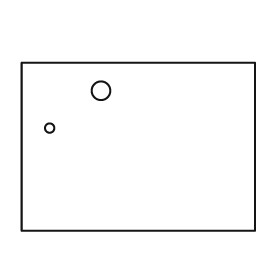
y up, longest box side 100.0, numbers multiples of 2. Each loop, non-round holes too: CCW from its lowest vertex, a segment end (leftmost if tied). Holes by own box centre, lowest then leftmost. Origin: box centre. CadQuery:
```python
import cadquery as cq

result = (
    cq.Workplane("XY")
    .moveTo(-50.0, -36.0)
    .lineTo(50.0, -36.0)
    .lineTo(50.0, 36.0)
    .lineTo(-50.0, 36.0)
    .close()
    .moveTo(-38.0, 8.0)
    .circle(2.0)
    .moveTo(-16.0, 24.0)
    .circle(4.0)
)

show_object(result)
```